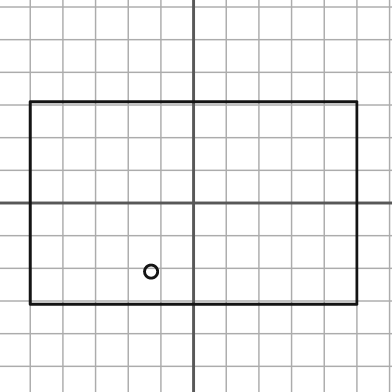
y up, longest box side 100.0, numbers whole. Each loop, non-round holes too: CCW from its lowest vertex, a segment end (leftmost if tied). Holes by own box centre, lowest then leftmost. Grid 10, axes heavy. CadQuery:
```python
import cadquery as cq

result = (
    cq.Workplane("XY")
    .moveTo(-50.0, -31.0)
    .lineTo(50.0, -31.0)
    .lineTo(50.0, 31.0)
    .lineTo(-50.0, 31.0)
    .close()
    .moveTo(-13.0, -21.0)
    .circle(2.0)
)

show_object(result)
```